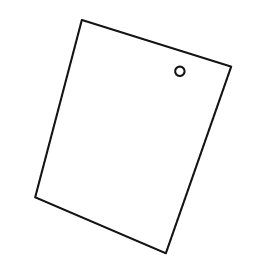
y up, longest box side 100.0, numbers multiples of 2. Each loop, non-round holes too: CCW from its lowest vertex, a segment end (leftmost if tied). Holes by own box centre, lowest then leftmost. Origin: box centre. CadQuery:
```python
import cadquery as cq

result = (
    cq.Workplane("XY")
    .moveTo(14.0, -50.0)
    .lineTo(42.0, 30.0)
    .lineTo(-22.0, 50.0)
    .lineTo(-42.0, -26.0)
    .close()
    .moveTo(20.0, 28.0)
    .circle(2.0)
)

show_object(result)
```